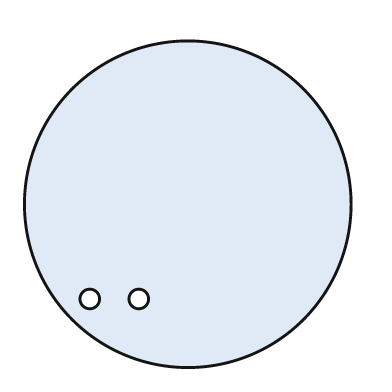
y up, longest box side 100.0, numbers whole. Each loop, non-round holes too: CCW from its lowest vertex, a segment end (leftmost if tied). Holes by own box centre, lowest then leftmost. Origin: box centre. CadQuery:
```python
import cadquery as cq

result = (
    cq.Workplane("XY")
    .moveTo(0.0, 0.0)
    .circle(50.0)
    .moveTo(-30.0, -29.0)
    .circle(3.0)
    .moveTo(-15.0, -29.0)
    .circle(3.0)
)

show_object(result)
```